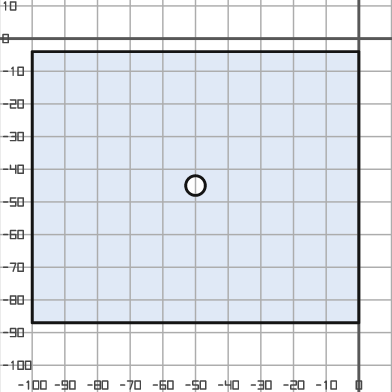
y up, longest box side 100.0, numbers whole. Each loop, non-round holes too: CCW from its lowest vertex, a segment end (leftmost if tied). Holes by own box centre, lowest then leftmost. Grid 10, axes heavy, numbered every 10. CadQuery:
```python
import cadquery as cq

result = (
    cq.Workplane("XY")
    .moveTo(-100.0, -87.0)
    .lineTo(0.0, -87.0)
    .lineTo(0.0, -4.0)
    .lineTo(-100.0, -4.0)
    .close()
    .moveTo(-50.0, -45.0)
    .circle(3.0)
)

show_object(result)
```